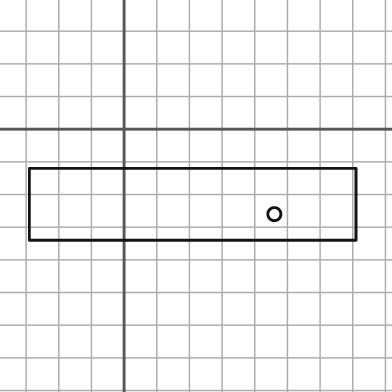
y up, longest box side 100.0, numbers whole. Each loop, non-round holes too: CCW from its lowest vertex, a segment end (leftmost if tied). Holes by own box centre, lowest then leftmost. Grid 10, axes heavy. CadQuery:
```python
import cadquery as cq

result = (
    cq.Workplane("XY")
    .moveTo(-29.0, -34.0)
    .lineTo(71.0, -34.0)
    .lineTo(71.0, -12.0)
    .lineTo(-29.0, -12.0)
    .close()
    .moveTo(46.0, -26.0)
    .circle(2.0)
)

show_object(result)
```